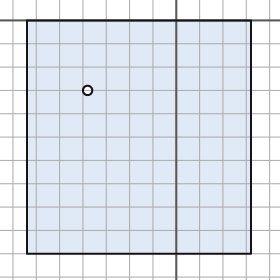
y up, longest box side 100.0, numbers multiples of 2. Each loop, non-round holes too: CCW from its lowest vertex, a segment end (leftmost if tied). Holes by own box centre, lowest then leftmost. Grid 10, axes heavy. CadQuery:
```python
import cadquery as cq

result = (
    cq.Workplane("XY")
    .moveTo(-64.0, -100.0)
    .lineTo(32.0, -100.0)
    .lineTo(32.0, 0.0)
    .lineTo(-64.0, 0.0)
    .close()
    .moveTo(-38.0, -30.0)
    .circle(2.0)
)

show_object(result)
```